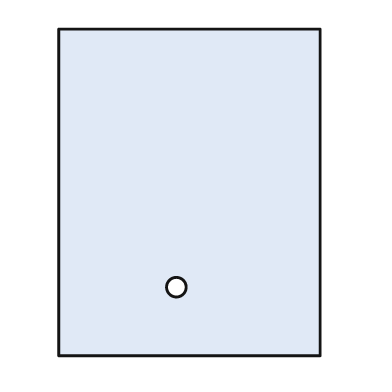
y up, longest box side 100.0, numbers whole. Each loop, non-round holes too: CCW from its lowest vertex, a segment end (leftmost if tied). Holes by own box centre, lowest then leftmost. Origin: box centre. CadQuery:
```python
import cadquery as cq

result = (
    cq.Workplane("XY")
    .moveTo(-40.0, -50.0)
    .lineTo(40.0, -50.0)
    .lineTo(40.0, 50.0)
    .lineTo(-40.0, 50.0)
    .close()
    .moveTo(-4.0, -29.0)
    .circle(3.0)
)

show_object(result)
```